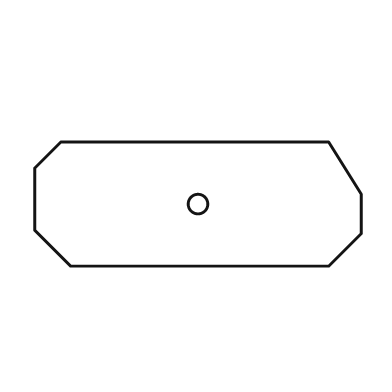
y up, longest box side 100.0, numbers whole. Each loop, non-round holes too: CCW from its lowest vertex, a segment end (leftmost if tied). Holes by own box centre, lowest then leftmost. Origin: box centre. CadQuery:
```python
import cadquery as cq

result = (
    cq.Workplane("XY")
    .moveTo(-39.0, -19.0)
    .lineTo(40.0, -19.0)
    .lineTo(50.0, -9.0)
    .lineTo(50.0, 3.0)
    .lineTo(40.0, 19.0)
    .lineTo(-42.0, 19.0)
    .lineTo(-50.0, 11.0)
    .lineTo(-50.0, -8.0)
    .close()
    .moveTo(0.0, 0.0)
    .circle(3.0)
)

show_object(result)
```